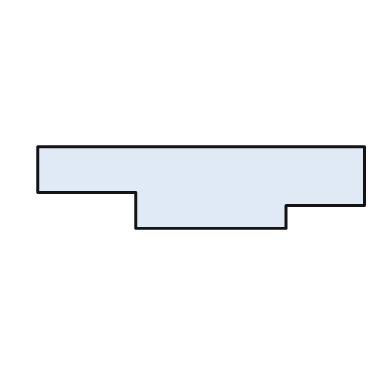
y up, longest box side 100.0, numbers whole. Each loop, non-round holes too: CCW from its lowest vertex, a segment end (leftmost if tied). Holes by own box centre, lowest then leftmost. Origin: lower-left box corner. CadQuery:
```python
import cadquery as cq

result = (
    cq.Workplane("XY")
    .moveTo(30.0, 0.0)
    .lineTo(76.0, 0.0)
    .lineTo(76.0, 7.0)
    .lineTo(100.0, 7.0)
    .lineTo(100.0, 25.0)
    .lineTo(0.0, 25.0)
    .lineTo(0.0, 11.0)
    .lineTo(30.0, 11.0)
    .close()
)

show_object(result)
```